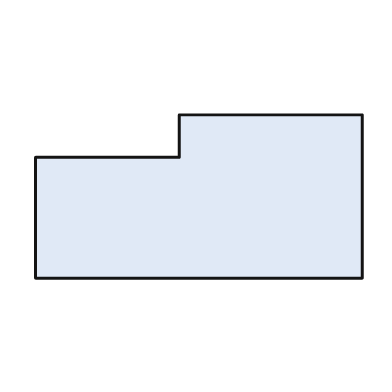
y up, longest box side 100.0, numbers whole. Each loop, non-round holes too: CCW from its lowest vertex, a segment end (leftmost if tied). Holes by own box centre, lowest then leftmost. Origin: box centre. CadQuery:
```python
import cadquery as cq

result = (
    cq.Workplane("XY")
    .moveTo(-50.0, -25.0)
    .lineTo(50.0, -25.0)
    .lineTo(50.0, 25.0)
    .lineTo(-6.0, 25.0)
    .lineTo(-6.0, 12.0)
    .lineTo(-50.0, 12.0)
    .close()
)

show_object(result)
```